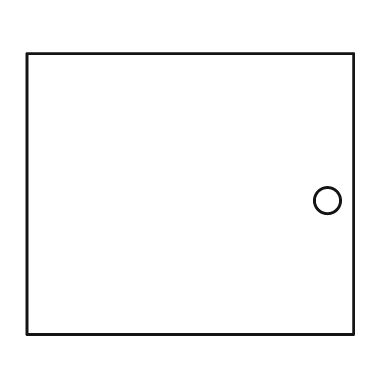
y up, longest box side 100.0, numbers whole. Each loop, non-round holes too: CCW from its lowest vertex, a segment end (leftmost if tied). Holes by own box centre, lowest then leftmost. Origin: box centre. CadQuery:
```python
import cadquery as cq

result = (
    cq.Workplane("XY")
    .moveTo(-50.0, -43.0)
    .lineTo(50.0, -43.0)
    .lineTo(50.0, 43.0)
    .lineTo(-50.0, 43.0)
    .close()
    .moveTo(42.0, -2.0)
    .circle(4.0)
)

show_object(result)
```